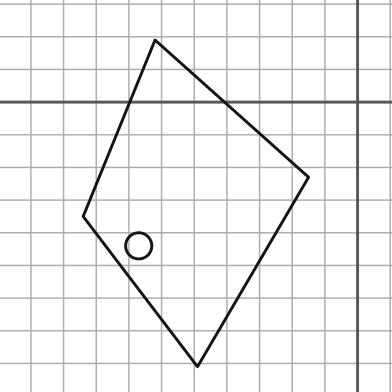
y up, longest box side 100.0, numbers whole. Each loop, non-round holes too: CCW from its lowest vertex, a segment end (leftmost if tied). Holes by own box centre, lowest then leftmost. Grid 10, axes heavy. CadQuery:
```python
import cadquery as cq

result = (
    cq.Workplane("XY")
    .moveTo(-49.0, -81.0)
    .lineTo(-15.0, -23.0)
    .lineTo(-62.0, 19.0)
    .lineTo(-84.0, -35.0)
    .close()
    .moveTo(-67.0, -44.0)
    .circle(4.0)
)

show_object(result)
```